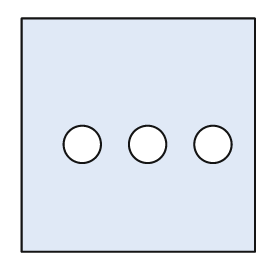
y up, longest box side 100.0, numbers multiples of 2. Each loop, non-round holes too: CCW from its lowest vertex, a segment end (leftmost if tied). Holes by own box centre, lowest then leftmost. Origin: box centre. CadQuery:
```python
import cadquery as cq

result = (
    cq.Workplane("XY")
    .moveTo(-50.0, -50.0)
    .lineTo(50.0, -50.0)
    .lineTo(50.0, 50.0)
    .lineTo(-50.0, 50.0)
    .close()
    .moveTo(-24.0, -4.0)
    .circle(8.0)
    .moveTo(4.0, -4.0)
    .circle(8.0)
    .moveTo(32.0, -4.0)
    .circle(8.0)
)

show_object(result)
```